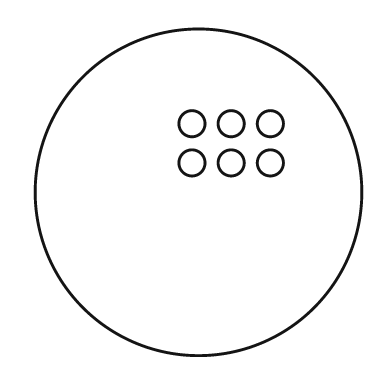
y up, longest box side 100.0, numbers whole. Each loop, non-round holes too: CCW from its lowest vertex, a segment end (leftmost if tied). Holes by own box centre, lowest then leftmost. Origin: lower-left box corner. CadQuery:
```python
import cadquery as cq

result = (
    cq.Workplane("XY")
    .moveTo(50.0, 50.0)
    .circle(50.0)
    .moveTo(48.0, 59.0)
    .circle(4.0)
    .moveTo(60.0, 59.0)
    .circle(4.0)
    .moveTo(72.0, 59.0)
    .circle(4.0)
    .moveTo(48.0, 71.0)
    .circle(4.0)
    .moveTo(60.0, 71.0)
    .circle(4.0)
    .moveTo(72.0, 71.0)
    .circle(4.0)
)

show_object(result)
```